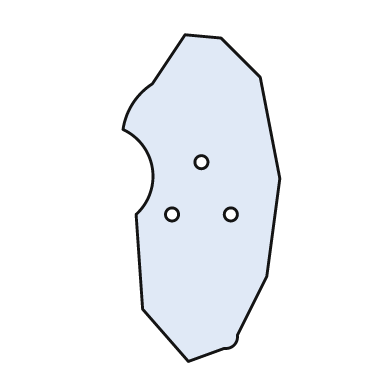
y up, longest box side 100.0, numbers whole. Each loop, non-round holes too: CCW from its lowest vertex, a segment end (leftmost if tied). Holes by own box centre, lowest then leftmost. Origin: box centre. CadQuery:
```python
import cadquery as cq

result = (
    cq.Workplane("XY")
    .moveTo(-4.0, -50.0)
    .lineTo(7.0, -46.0)
    .threePointArc((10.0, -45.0), (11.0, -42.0))
    .lineTo(20.0, -24.0)
    .lineTo(24.0, 6.0)
    .lineTo(18.0, 37.0)
    .lineTo(6.0, 49.0)
    .lineTo(-5.0, 50.0)
    .lineTo(-15.0, 35.0)
    .threePointArc((-21.0, 29.0), (-24.0, 21.0))
    .threePointArc((-15.0, 9.0), (-20.0, -5.0))
    .lineTo(-18.0, -34.0)
    .close()
    .moveTo(-9.0, -5.0)
    .circle(2.0)
    .moveTo(9.0, -5.0)
    .circle(2.0)
    .moveTo(0.0, 11.0)
    .circle(2.0)
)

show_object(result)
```